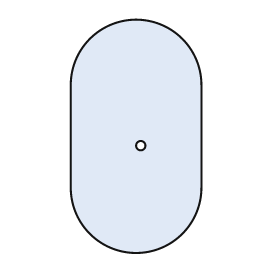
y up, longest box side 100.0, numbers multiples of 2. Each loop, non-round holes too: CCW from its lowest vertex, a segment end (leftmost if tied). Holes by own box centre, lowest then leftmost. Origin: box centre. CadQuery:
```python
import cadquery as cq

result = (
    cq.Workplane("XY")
    .moveTo(-28.0, -22.0)
    .threePointArc((0.0, -50.0), (28.0, -22.0))
    .lineTo(28.0, 22.0)
    .threePointArc((0.0, 50.0), (-28.0, 22.0))
    .close()
    .moveTo(2.0, -4.0)
    .circle(2.0)
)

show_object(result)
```